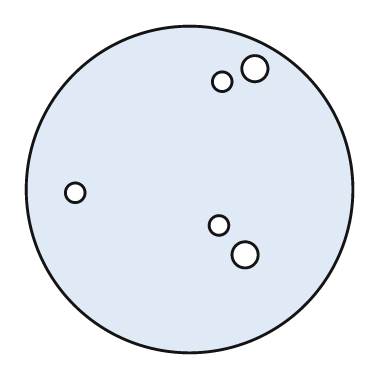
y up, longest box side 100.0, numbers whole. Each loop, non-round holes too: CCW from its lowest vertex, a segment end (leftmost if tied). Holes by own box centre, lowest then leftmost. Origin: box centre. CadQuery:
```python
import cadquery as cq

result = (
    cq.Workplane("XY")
    .moveTo(0.0, 0.0)
    .circle(50.0)
    .moveTo(17.0, -20.0)
    .circle(4.0)
    .moveTo(9.0, -11.0)
    .circle(3.0)
    .moveTo(-35.0, -1.0)
    .circle(3.0)
    .moveTo(10.0, 33.0)
    .circle(3.0)
    .moveTo(20.0, 37.0)
    .circle(4.0)
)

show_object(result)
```